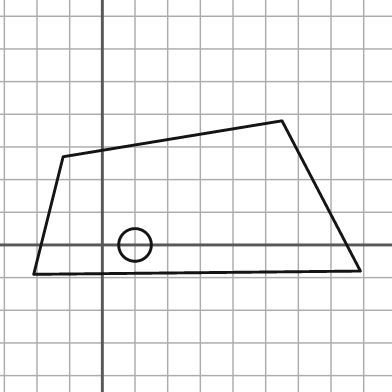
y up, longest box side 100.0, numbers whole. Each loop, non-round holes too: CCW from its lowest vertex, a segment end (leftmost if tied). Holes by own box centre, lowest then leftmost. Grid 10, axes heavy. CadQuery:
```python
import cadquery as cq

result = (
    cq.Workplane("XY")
    .moveTo(-21.0, -9.0)
    .lineTo(79.0, -8.0)
    .lineTo(55.0, 38.0)
    .lineTo(-12.0, 27.0)
    .close()
    .moveTo(10.0, 0.0)
    .circle(5.0)
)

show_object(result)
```